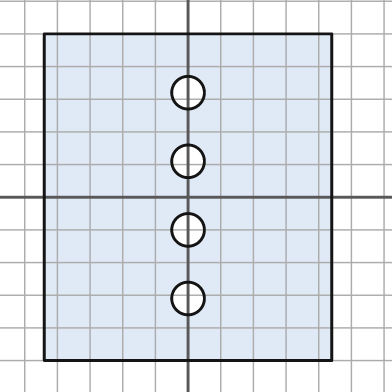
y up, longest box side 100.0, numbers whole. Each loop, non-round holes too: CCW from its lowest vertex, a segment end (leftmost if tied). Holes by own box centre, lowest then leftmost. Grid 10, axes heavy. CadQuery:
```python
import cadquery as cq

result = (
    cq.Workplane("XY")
    .moveTo(-44.0, -50.0)
    .lineTo(44.0, -50.0)
    .lineTo(44.0, 50.0)
    .lineTo(-44.0, 50.0)
    .close()
    .moveTo(0.0, -31.0)
    .circle(5.0)
    .moveTo(0.0, -10.0)
    .circle(5.0)
    .moveTo(0.0, 11.0)
    .circle(5.0)
    .moveTo(0.0, 32.0)
    .circle(5.0)
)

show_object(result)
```